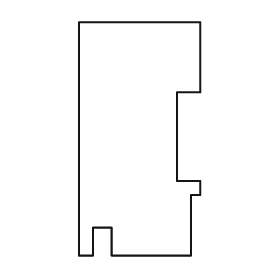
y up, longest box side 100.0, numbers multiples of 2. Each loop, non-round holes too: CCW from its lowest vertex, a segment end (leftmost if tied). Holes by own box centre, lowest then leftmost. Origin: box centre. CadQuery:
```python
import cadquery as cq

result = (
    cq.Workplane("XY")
    .moveTo(-26.0, -50.0)
    .lineTo(-20.0, -50.0)
    .lineTo(-20.0, -38.0)
    .lineTo(-12.0, -38.0)
    .lineTo(-12.0, -50.0)
    .lineTo(22.0, -50.0)
    .lineTo(22.0, -24.0)
    .lineTo(26.0, -24.0)
    .lineTo(26.0, -18.0)
    .lineTo(16.0, -18.0)
    .lineTo(16.0, 20.0)
    .lineTo(26.0, 20.0)
    .lineTo(26.0, 50.0)
    .lineTo(-26.0, 50.0)
    .close()
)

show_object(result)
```